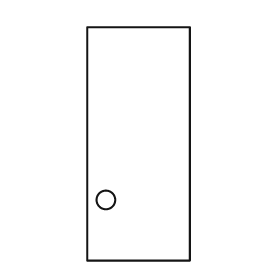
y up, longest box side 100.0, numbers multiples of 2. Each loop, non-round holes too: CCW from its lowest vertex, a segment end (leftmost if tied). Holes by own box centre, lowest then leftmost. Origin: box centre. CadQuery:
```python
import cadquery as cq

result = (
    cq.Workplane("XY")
    .moveTo(-22.0, -50.0)
    .lineTo(22.0, -50.0)
    .lineTo(22.0, 50.0)
    .lineTo(-22.0, 50.0)
    .close()
    .moveTo(-14.0, -24.0)
    .circle(4.0)
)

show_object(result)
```